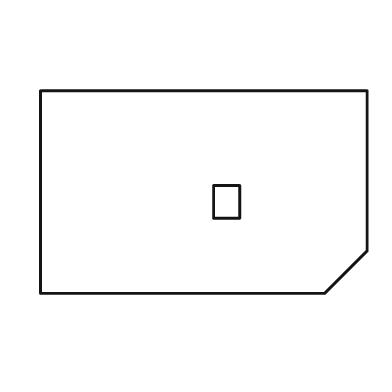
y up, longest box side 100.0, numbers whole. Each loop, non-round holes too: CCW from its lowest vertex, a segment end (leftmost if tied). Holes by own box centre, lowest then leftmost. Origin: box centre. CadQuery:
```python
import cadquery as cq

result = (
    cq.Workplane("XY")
    .moveTo(-50.0, -31.0)
    .lineTo(37.0, -31.0)
    .lineTo(50.0, -18.0)
    .lineTo(50.0, 31.0)
    .lineTo(-50.0, 31.0)
    .close()
    .moveTo(3.0, -8.0)
    .lineTo(11.0, -8.0)
    .lineTo(11.0, 2.0)
    .lineTo(3.0, 2.0)
    .close()
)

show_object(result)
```